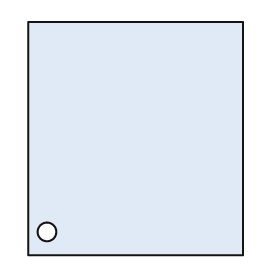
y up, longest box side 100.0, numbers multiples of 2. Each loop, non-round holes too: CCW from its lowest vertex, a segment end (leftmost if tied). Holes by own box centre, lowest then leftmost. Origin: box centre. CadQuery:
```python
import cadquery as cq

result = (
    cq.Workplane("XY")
    .moveTo(-46.0, -50.0)
    .lineTo(46.0, -50.0)
    .lineTo(46.0, 50.0)
    .lineTo(-46.0, 50.0)
    .close()
    .moveTo(-38.0, -40.0)
    .circle(4.0)
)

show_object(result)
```